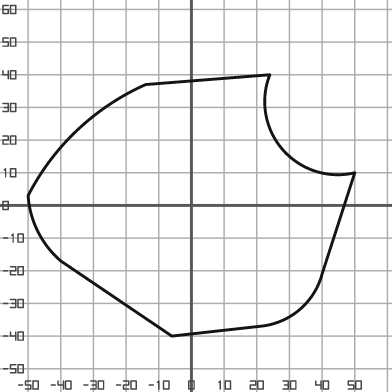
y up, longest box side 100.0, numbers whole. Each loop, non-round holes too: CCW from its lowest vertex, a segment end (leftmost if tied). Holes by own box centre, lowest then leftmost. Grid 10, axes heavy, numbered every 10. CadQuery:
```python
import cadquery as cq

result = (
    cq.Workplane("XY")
    .moveTo(-6.0, -40.0)
    .lineTo(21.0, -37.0)
    .threePointArc((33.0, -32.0), (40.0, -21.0))
    .lineTo(50.0, 10.0)
    .threePointArc((28.0, 17.0), (24.0, 40.0))
    .lineTo(-14.0, 37.0)
    .threePointArc((-35.0, 23.0), (-50.0, 3.0))
    .threePointArc((-47.0, -8.0), (-40.0, -17.0))
    .close()
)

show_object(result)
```